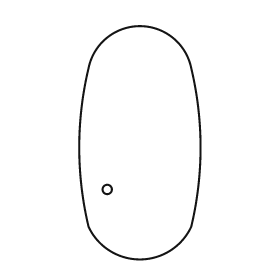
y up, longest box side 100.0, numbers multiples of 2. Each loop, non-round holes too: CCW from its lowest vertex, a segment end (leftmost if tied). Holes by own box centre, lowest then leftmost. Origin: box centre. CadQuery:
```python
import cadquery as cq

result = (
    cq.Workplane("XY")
    .moveTo(-22.0, -36.0)
    .threePointArc((0.0, -50.0), (22.0, -36.0))
    .threePointArc((26.0, -2.0), (22.0, 32.0))
    .threePointArc((0.0, 50.0), (-22.0, 32.0))
    .threePointArc((-26.0, -2.0), (-22.0, -36.0))
    .close()
    .moveTo(-14.0, -20.0)
    .circle(2.0)
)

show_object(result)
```